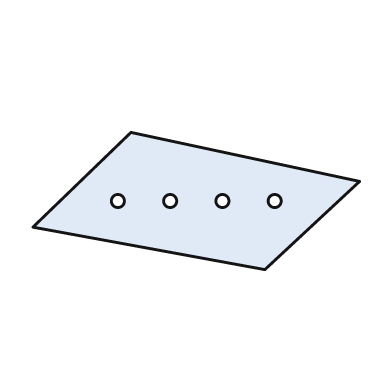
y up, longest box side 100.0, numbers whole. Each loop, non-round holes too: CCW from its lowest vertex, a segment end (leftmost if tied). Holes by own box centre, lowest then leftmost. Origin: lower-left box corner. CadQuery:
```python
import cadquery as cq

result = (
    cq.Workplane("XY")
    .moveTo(71.0, 0.0)
    .lineTo(100.0, 27.0)
    .lineTo(30.0, 42.0)
    .lineTo(0.0, 13.0)
    .close()
    .moveTo(26.0, 21.0)
    .circle(2.0)
    .moveTo(42.0, 21.0)
    .circle(2.0)
    .moveTo(58.0, 21.0)
    .circle(2.0)
    .moveTo(74.0, 21.0)
    .circle(2.0)
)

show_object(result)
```